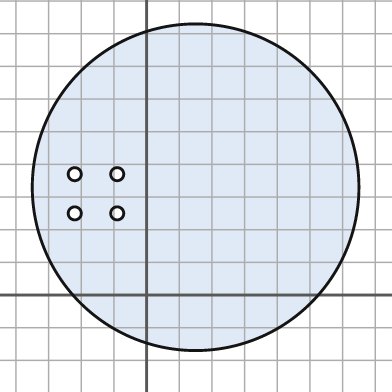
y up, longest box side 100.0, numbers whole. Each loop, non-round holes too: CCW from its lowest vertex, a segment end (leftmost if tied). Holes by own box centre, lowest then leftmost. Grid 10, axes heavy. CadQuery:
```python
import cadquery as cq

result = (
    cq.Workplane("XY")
    .moveTo(15.0, 33.0)
    .circle(50.0)
    .moveTo(-22.0, 25.0)
    .circle(2.0)
    .moveTo(-9.0, 25.0)
    .circle(2.0)
    .moveTo(-22.0, 37.0)
    .circle(2.0)
    .moveTo(-9.0, 37.0)
    .circle(2.0)
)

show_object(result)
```